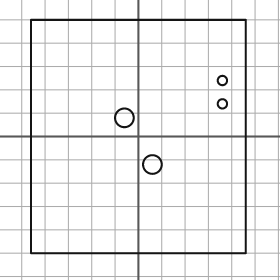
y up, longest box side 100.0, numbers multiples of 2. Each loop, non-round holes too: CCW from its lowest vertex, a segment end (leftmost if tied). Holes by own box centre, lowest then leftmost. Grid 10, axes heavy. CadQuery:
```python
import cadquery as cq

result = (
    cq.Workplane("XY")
    .moveTo(-46.0, -50.0)
    .lineTo(46.0, -50.0)
    .lineTo(46.0, 50.0)
    .lineTo(-46.0, 50.0)
    .close()
    .moveTo(6.0, -12.0)
    .circle(4.0)
    .moveTo(-6.0, 8.0)
    .circle(4.0)
    .moveTo(36.0, 14.0)
    .circle(2.0)
    .moveTo(36.0, 24.0)
    .circle(2.0)
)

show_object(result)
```